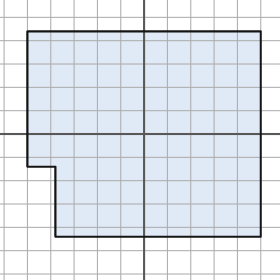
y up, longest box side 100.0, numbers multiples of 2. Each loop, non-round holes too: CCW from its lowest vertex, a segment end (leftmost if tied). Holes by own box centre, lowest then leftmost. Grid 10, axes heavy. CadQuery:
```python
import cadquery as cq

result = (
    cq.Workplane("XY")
    .moveTo(-38.0, -44.0)
    .lineTo(50.0, -44.0)
    .lineTo(50.0, 44.0)
    .lineTo(-50.0, 44.0)
    .lineTo(-50.0, -14.0)
    .lineTo(-38.0, -14.0)
    .close()
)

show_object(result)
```